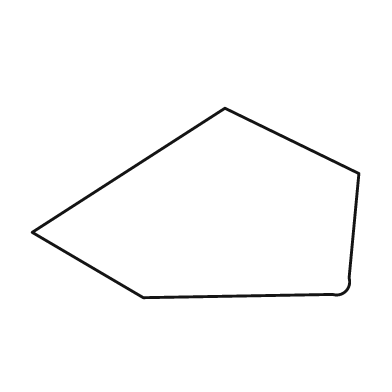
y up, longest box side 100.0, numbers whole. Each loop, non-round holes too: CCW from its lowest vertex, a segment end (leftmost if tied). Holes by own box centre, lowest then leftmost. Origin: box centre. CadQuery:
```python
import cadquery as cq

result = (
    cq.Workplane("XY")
    .moveTo(-16.0, -29.0)
    .lineTo(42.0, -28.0)
    .threePointArc((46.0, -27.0), (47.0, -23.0))
    .lineTo(50.0, 9.0)
    .lineTo(9.0, 29.0)
    .lineTo(-50.0, -9.0)
    .close()
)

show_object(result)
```